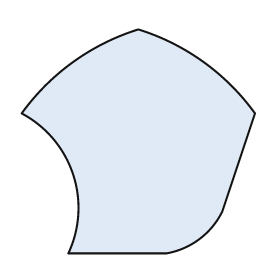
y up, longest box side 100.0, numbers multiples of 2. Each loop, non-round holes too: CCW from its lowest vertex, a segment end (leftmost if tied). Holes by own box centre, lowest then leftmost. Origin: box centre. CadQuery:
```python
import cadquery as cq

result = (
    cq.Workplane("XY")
    .moveTo(-30.0, -48.0)
    .lineTo(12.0, -48.0)
    .threePointArc((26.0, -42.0), (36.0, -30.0))
    .lineTo(50.0, 12.0)
    .threePointArc((28.0, 34.0), (0.0, 48.0))
    .threePointArc((-28.0, 34.0), (-50.0, 12.0))
    .threePointArc((-28.0, -14.0), (-30.0, -48.0))
    .close()
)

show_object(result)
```